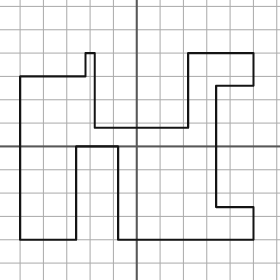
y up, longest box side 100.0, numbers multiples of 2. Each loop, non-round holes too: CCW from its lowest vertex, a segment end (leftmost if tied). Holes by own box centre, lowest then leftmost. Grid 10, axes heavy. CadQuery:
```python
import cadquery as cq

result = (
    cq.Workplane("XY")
    .moveTo(-50.0, -40.0)
    .lineTo(-26.0, -40.0)
    .lineTo(-26.0, 0.0)
    .lineTo(-8.0, 0.0)
    .lineTo(-8.0, -40.0)
    .lineTo(50.0, -40.0)
    .lineTo(50.0, -26.0)
    .lineTo(34.0, -26.0)
    .lineTo(34.0, 26.0)
    .lineTo(50.0, 26.0)
    .lineTo(50.0, 40.0)
    .lineTo(22.0, 40.0)
    .lineTo(22.0, 8.0)
    .lineTo(-18.0, 8.0)
    .lineTo(-18.0, 40.0)
    .lineTo(-22.0, 40.0)
    .lineTo(-22.0, 30.0)
    .lineTo(-50.0, 30.0)
    .close()
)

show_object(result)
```